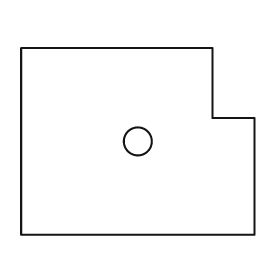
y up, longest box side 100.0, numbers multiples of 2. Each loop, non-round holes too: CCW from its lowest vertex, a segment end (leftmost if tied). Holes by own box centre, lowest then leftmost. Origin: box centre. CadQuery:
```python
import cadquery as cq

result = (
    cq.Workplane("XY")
    .moveTo(-50.0, -40.0)
    .lineTo(50.0, -40.0)
    .lineTo(50.0, 10.0)
    .lineTo(32.0, 10.0)
    .lineTo(32.0, 40.0)
    .lineTo(-50.0, 40.0)
    .close()
    .moveTo(0.0, 0.0)
    .circle(6.0)
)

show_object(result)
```